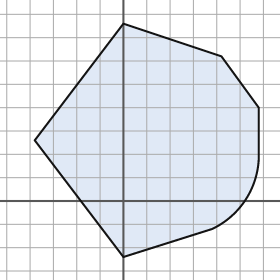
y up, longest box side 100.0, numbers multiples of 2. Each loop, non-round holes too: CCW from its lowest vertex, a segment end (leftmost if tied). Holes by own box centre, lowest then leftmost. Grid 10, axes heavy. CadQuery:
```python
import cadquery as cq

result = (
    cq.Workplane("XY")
    .moveTo(0.0, -24.0)
    .lineTo(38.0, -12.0)
    .threePointArc((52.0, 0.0), (58.0, 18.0))
    .lineTo(58.0, 40.0)
    .lineTo(42.0, 62.0)
    .lineTo(0.0, 76.0)
    .lineTo(-38.0, 26.0)
    .close()
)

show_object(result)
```